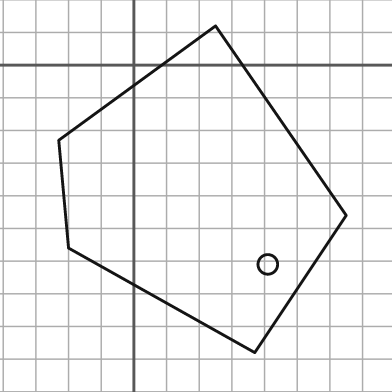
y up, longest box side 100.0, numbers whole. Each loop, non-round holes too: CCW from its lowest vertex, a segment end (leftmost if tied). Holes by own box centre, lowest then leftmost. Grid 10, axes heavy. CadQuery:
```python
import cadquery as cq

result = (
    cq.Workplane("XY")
    .moveTo(37.0, -88.0)
    .lineTo(65.0, -46.0)
    .lineTo(25.0, 12.0)
    .lineTo(-23.0, -23.0)
    .lineTo(-20.0, -56.0)
    .close()
    .moveTo(41.0, -61.0)
    .circle(3.0)
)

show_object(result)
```